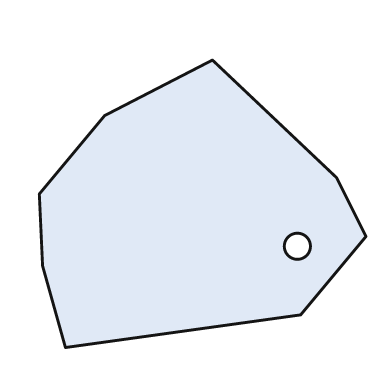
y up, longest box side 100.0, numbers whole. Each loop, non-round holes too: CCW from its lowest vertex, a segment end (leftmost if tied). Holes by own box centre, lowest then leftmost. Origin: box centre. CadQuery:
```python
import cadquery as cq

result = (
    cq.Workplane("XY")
    .moveTo(-42.0, -44.0)
    .lineTo(30.0, -34.0)
    .lineTo(50.0, -10.0)
    .lineTo(41.0, 8.0)
    .lineTo(3.0, 44.0)
    .lineTo(-30.0, 27.0)
    .lineTo(-50.0, 3.0)
    .lineTo(-49.0, -19.0)
    .close()
    .moveTo(29.0, -13.0)
    .circle(4.0)
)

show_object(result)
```